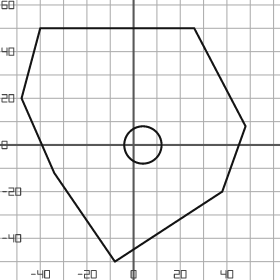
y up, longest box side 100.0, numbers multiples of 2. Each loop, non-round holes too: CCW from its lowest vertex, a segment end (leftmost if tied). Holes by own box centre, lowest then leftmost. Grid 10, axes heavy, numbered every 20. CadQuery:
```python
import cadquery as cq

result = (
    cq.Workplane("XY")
    .moveTo(-8.0, -50.0)
    .lineTo(38.0, -20.0)
    .lineTo(48.0, 8.0)
    .lineTo(26.0, 50.0)
    .lineTo(-40.0, 50.0)
    .lineTo(-48.0, 20.0)
    .lineTo(-34.0, -12.0)
    .close()
    .moveTo(4.0, 0.0)
    .circle(8.0)
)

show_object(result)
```